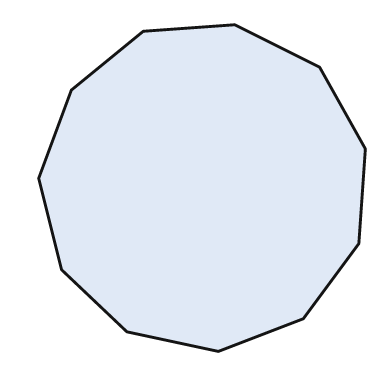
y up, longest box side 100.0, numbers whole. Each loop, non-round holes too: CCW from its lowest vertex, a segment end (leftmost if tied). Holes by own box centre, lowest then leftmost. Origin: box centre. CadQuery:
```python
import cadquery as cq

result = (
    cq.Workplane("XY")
    .moveTo(5.0, -50.0)
    .lineTo(31.0, -40.0)
    .lineTo(48.0, -17.0)
    .lineTo(50.0, 12.0)
    .lineTo(36.0, 37.0)
    .lineTo(10.0, 50.0)
    .lineTo(-18.0, 48.0)
    .lineTo(-40.0, 30.0)
    .lineTo(-50.0, 3.0)
    .lineTo(-43.0, -25.0)
    .lineTo(-23.0, -44.0)
    .close()
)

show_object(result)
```